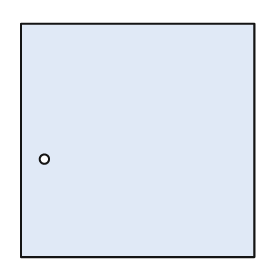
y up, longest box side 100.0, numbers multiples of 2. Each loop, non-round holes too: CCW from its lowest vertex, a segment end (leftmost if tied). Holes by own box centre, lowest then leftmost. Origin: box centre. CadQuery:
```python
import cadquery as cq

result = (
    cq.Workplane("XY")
    .moveTo(-50.0, -50.0)
    .lineTo(50.0, -50.0)
    .lineTo(50.0, 50.0)
    .lineTo(-50.0, 50.0)
    .close()
    .moveTo(-40.0, -8.0)
    .circle(2.0)
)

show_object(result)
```